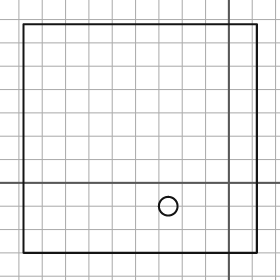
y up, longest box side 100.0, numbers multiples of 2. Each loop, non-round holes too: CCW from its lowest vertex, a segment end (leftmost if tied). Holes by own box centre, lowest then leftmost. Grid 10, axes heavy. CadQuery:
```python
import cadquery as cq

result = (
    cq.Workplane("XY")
    .moveTo(-88.0, -30.0)
    .lineTo(12.0, -30.0)
    .lineTo(12.0, 68.0)
    .lineTo(-88.0, 68.0)
    .close()
    .moveTo(-26.0, -10.0)
    .circle(4.0)
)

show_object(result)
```